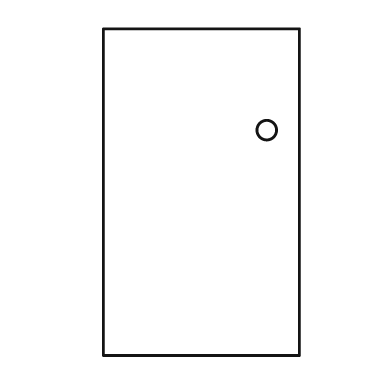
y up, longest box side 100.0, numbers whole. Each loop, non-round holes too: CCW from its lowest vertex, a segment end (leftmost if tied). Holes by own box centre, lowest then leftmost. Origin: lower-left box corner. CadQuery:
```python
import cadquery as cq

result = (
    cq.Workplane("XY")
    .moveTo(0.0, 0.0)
    .lineTo(60.0, 0.0)
    .lineTo(60.0, 100.0)
    .lineTo(0.0, 100.0)
    .close()
    .moveTo(50.0, 69.0)
    .circle(3.0)
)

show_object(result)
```